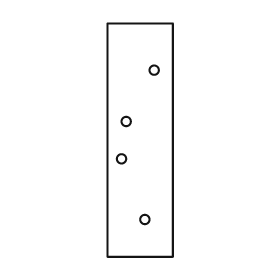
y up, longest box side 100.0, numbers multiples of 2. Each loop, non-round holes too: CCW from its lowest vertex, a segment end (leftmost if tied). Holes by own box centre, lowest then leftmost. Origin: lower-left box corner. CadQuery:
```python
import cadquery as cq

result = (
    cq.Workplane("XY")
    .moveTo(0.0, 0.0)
    .lineTo(28.0, 0.0)
    .lineTo(28.0, 100.0)
    .lineTo(0.0, 100.0)
    .close()
    .moveTo(16.0, 16.0)
    .circle(2.0)
    .moveTo(6.0, 42.0)
    .circle(2.0)
    .moveTo(8.0, 58.0)
    .circle(2.0)
    .moveTo(20.0, 80.0)
    .circle(2.0)
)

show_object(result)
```